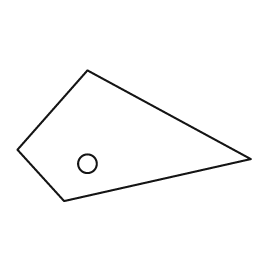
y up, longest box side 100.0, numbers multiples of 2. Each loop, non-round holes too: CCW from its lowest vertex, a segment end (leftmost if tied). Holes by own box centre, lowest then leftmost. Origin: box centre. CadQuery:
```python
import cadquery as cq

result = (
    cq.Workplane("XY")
    .moveTo(-30.0, -28.0)
    .lineTo(50.0, -10.0)
    .lineTo(-20.0, 28.0)
    .lineTo(-50.0, -6.0)
    .close()
    .moveTo(-20.0, -12.0)
    .circle(4.0)
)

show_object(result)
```